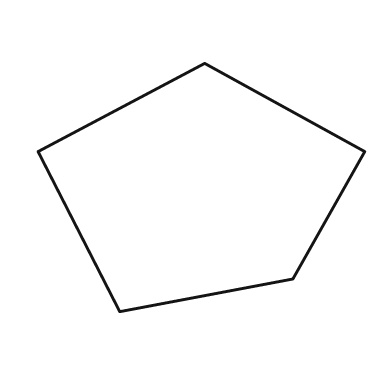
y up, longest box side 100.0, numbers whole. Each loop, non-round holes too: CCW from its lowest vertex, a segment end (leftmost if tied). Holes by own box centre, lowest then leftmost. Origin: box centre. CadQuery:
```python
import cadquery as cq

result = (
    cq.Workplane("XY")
    .moveTo(-25.0, -38.0)
    .lineTo(28.0, -28.0)
    .lineTo(50.0, 11.0)
    .lineTo(1.0, 38.0)
    .lineTo(-50.0, 11.0)
    .close()
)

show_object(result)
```